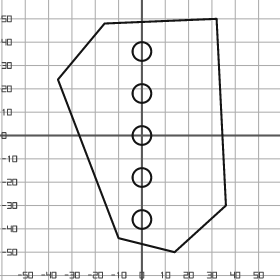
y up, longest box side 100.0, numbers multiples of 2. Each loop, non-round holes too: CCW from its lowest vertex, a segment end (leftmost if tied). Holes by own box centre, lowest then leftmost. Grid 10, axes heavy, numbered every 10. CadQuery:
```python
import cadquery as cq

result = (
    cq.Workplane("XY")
    .moveTo(14.0, -50.0)
    .lineTo(36.0, -30.0)
    .lineTo(32.0, 50.0)
    .lineTo(-16.0, 48.0)
    .lineTo(-36.0, 24.0)
    .lineTo(-10.0, -44.0)
    .close()
    .moveTo(0.0, -36.0)
    .circle(4.0)
    .moveTo(0.0, -18.0)
    .circle(4.0)
    .moveTo(0.0, 0.0)
    .circle(4.0)
    .moveTo(0.0, 18.0)
    .circle(4.0)
    .moveTo(0.0, 36.0)
    .circle(4.0)
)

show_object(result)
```